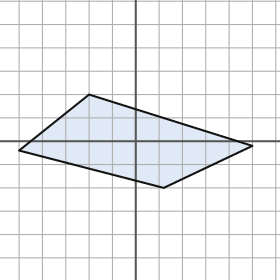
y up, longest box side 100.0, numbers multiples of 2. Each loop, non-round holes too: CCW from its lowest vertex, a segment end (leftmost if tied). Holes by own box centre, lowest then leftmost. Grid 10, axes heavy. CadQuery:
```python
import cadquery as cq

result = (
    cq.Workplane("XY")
    .moveTo(12.0, -20.0)
    .lineTo(50.0, -2.0)
    .lineTo(-20.0, 20.0)
    .lineTo(-50.0, -4.0)
    .close()
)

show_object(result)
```